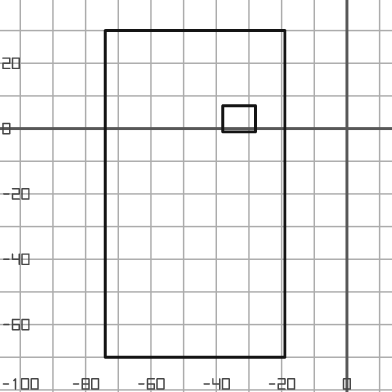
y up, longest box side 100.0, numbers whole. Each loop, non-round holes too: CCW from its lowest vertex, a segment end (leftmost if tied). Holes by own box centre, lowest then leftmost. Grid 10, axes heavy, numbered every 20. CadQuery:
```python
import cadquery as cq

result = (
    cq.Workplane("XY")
    .moveTo(-74.0, -70.0)
    .lineTo(-19.0, -70.0)
    .lineTo(-19.0, 30.0)
    .lineTo(-74.0, 30.0)
    .close()
    .moveTo(-38.0, -1.0)
    .lineTo(-28.0, -1.0)
    .lineTo(-28.0, 7.0)
    .lineTo(-38.0, 7.0)
    .close()
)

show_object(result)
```